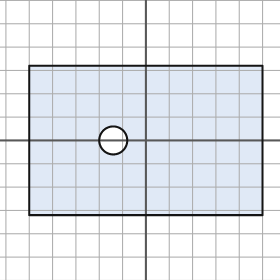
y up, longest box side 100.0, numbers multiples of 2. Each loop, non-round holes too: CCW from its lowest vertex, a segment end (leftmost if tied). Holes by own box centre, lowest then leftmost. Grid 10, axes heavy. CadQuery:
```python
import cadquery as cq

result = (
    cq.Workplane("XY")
    .moveTo(-50.0, -32.0)
    .lineTo(50.0, -32.0)
    .lineTo(50.0, 32.0)
    .lineTo(-50.0, 32.0)
    .close()
    .moveTo(-14.0, 0.0)
    .circle(6.0)
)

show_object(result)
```